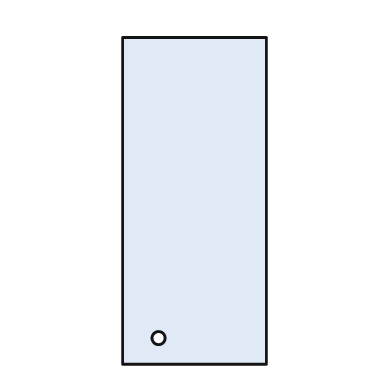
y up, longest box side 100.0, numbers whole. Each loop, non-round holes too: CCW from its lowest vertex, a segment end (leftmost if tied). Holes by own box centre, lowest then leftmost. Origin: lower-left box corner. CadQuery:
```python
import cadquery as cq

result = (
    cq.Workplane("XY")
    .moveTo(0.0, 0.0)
    .lineTo(44.0, 0.0)
    .lineTo(44.0, 100.0)
    .lineTo(0.0, 100.0)
    .close()
    .moveTo(11.0, 8.0)
    .circle(2.0)
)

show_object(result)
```